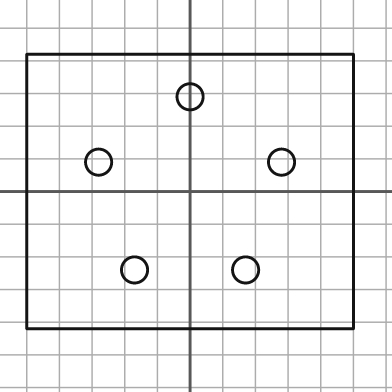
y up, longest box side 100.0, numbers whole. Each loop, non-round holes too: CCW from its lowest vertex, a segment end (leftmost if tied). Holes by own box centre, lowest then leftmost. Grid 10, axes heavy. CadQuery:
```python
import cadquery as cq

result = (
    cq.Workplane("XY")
    .moveTo(-50.0, -42.0)
    .lineTo(50.0, -42.0)
    .lineTo(50.0, 42.0)
    .lineTo(-50.0, 42.0)
    .close()
    .moveTo(-17.0, -24.0)
    .circle(4.0)
    .moveTo(17.0, -24.0)
    .circle(4.0)
    .moveTo(-28.0, 9.0)
    .circle(4.0)
    .moveTo(28.0, 9.0)
    .circle(4.0)
    .moveTo(0.0, 29.0)
    .circle(4.0)
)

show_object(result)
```